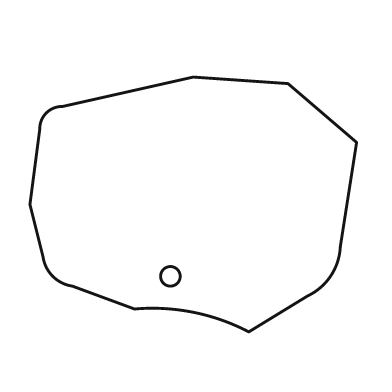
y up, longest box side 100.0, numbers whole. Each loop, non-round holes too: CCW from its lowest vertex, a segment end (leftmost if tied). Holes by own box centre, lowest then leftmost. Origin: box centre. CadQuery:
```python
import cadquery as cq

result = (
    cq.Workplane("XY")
    .moveTo(17.0, -39.0)
    .lineTo(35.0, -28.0)
    .threePointArc((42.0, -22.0), (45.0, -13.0))
    .lineTo(50.0, 19.0)
    .lineTo(29.0, 37.0)
    .lineTo(0.0, 39.0)
    .lineTo(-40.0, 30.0)
    .threePointArc((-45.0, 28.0), (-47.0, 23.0))
    .lineTo(-50.0, 0.0)
    .lineTo(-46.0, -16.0)
    .threePointArc((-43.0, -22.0), (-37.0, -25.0))
    .lineTo(-18.0, -32.0)
    .threePointArc((0.0, -33.0), (17.0, -39.0))
    .close()
    .moveTo(-7.0, -22.0)
    .circle(3.0)
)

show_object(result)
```